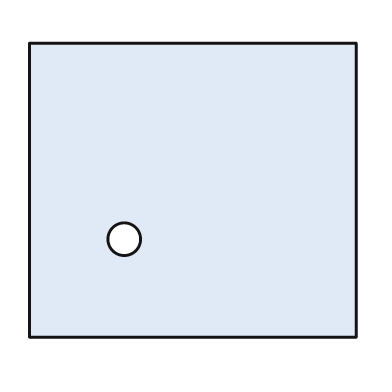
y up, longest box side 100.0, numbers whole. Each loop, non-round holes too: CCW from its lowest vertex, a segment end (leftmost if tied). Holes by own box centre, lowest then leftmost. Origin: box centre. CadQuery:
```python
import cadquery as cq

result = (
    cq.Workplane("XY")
    .moveTo(-50.0, -45.0)
    .lineTo(50.0, -45.0)
    .lineTo(50.0, 45.0)
    .lineTo(-50.0, 45.0)
    .close()
    .moveTo(-21.0, -15.0)
    .circle(5.0)
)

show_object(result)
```